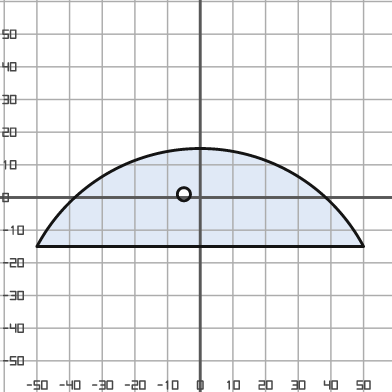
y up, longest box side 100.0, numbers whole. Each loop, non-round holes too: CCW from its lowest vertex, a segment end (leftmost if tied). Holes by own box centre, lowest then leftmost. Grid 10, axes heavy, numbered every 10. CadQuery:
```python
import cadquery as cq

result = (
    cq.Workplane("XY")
    .moveTo(-50.0, -15.0)
    .lineTo(50.0, -15.0)
    .threePointArc((0.0, 15.0), (-50.0, -15.0))
    .close()
    .moveTo(-5.0, 1.0)
    .circle(2.0)
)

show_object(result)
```